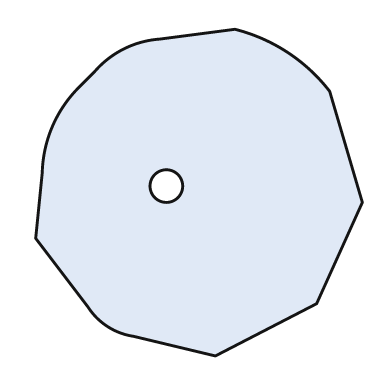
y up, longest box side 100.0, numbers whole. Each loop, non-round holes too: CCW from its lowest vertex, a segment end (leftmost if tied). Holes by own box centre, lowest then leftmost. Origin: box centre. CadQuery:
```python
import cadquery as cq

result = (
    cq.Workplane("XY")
    .moveTo(5.0, -50.0)
    .lineTo(36.0, -34.0)
    .lineTo(50.0, -3.0)
    .lineTo(40.0, 31.0)
    .threePointArc((27.0, 43.0), (11.0, 50.0))
    .lineTo(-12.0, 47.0)
    .threePointArc((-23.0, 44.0), (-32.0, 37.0))
    .lineTo(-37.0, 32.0)
    .threePointArc((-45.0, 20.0), (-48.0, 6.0))
    .lineTo(-50.0, -14.0)
    .lineTo(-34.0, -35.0)
    .threePointArc((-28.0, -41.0), (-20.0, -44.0))
    .close()
    .moveTo(-10.0, 2.0)
    .circle(5.0)
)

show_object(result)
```